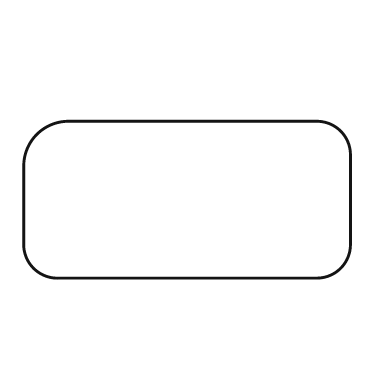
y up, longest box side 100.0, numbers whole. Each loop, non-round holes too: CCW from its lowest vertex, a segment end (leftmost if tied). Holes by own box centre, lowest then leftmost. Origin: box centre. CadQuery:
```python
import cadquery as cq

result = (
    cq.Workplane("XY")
    .moveTo(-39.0, -24.0)
    .lineTo(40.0, -24.0)
    .threePointArc((47.0, -21.0), (50.0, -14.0))
    .lineTo(50.0, 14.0)
    .threePointArc((47.0, 21.0), (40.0, 24.0))
    .lineTo(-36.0, 24.0)
    .threePointArc((-46.0, 20.0), (-50.0, 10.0))
    .lineTo(-50.0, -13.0)
    .threePointArc((-47.0, -21.0), (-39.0, -24.0))
    .close()
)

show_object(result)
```